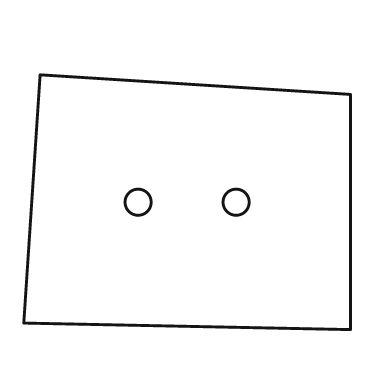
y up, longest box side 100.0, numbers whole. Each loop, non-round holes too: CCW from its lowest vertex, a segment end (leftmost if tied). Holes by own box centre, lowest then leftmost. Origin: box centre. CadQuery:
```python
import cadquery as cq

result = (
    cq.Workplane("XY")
    .moveTo(50.0, -39.0)
    .lineTo(50.0, 33.0)
    .lineTo(-45.0, 39.0)
    .lineTo(-50.0, -37.0)
    .close()
    .moveTo(-15.0, 0.0)
    .circle(4.0)
    .moveTo(15.0, 0.0)
    .circle(4.0)
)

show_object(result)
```